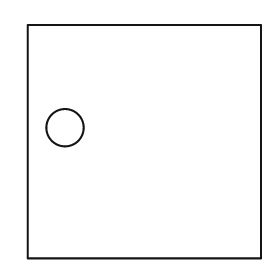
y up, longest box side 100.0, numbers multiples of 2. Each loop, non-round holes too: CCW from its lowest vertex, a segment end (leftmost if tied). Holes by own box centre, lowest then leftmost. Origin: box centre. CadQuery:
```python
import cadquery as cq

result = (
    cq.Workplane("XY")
    .moveTo(-50.0, -50.0)
    .lineTo(50.0, -50.0)
    .lineTo(50.0, 50.0)
    .lineTo(-50.0, 50.0)
    .close()
    .moveTo(-34.0, 6.0)
    .circle(8.0)
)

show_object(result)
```